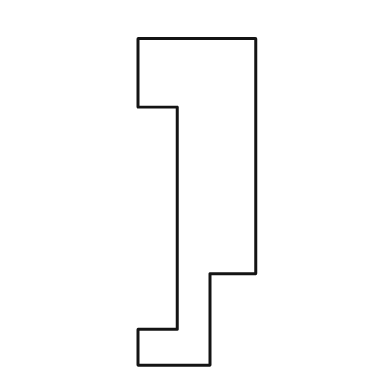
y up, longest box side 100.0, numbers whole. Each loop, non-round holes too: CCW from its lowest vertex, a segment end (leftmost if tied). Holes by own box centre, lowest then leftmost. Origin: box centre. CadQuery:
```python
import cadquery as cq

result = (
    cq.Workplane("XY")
    .moveTo(-18.0, -50.0)
    .lineTo(4.0, -50.0)
    .lineTo(4.0, -22.0)
    .lineTo(18.0, -22.0)
    .lineTo(18.0, 50.0)
    .lineTo(-18.0, 50.0)
    .lineTo(-18.0, 29.0)
    .lineTo(-6.0, 29.0)
    .lineTo(-6.0, -39.0)
    .lineTo(-18.0, -39.0)
    .close()
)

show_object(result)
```